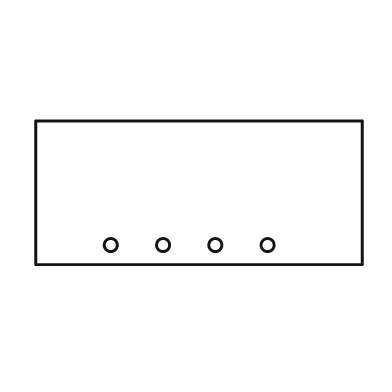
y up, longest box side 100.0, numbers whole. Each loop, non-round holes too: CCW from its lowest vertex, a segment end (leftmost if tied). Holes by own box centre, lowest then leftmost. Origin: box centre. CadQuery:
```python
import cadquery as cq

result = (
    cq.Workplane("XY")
    .moveTo(-50.0, -22.0)
    .lineTo(50.0, -22.0)
    .lineTo(50.0, 22.0)
    .lineTo(-50.0, 22.0)
    .close()
    .moveTo(-27.0, -16.0)
    .circle(2.0)
    .moveTo(-11.0, -16.0)
    .circle(2.0)
    .moveTo(5.0, -16.0)
    .circle(2.0)
    .moveTo(21.0, -16.0)
    .circle(2.0)
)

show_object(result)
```